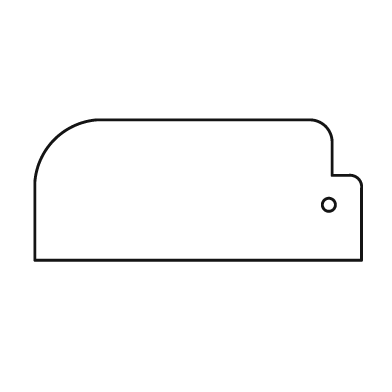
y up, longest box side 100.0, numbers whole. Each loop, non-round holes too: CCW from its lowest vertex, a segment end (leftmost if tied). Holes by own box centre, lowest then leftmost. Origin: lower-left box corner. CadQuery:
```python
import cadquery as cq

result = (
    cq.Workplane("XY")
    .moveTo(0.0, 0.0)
    .lineTo(100.0, 0.0)
    .lineTo(100.0, 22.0)
    .threePointArc((99.0, 25.0), (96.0, 26.0))
    .lineTo(91.0, 26.0)
    .lineTo(91.0, 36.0)
    .threePointArc((89.0, 41.0), (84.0, 43.0))
    .lineTo(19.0, 43.0)
    .threePointArc((6.0, 37.0), (0.0, 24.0))
    .close()
    .moveTo(90.0, 17.0)
    .circle(2.0)
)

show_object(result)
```